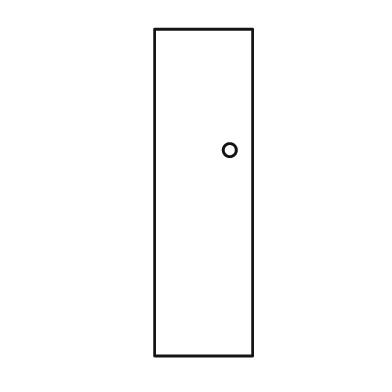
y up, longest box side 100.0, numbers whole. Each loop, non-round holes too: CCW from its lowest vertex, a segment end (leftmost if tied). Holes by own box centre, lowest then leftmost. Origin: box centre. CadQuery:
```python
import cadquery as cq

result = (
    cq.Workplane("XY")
    .moveTo(-15.0, -50.0)
    .lineTo(15.0, -50.0)
    .lineTo(15.0, 50.0)
    .lineTo(-15.0, 50.0)
    .close()
    .moveTo(8.0, 13.0)
    .circle(2.0)
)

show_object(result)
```